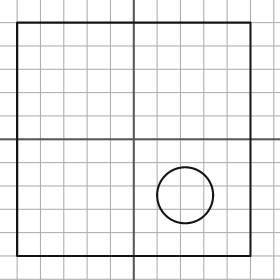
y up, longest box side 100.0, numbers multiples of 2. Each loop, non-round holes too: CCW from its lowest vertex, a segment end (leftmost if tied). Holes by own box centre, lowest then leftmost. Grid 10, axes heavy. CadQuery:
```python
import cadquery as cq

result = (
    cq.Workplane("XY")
    .moveTo(-50.0, -50.0)
    .lineTo(50.0, -50.0)
    .lineTo(50.0, 50.0)
    .lineTo(-50.0, 50.0)
    .close()
    .moveTo(22.0, -24.0)
    .circle(12.0)
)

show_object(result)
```